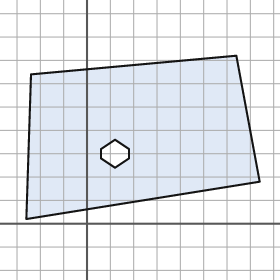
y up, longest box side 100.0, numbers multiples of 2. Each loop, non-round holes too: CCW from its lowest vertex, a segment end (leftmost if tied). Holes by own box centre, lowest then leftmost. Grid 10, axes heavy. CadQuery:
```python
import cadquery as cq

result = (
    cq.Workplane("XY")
    .moveTo(-26.0, 2.0)
    .lineTo(74.0, 18.0)
    .lineTo(64.0, 72.0)
    .lineTo(-24.0, 64.0)
    .close()
    .moveTo(12.0, 24.0)
    .lineTo(18.0, 28.0)
    .lineTo(18.0, 32.0)
    .lineTo(12.0, 36.0)
    .lineTo(6.0, 32.0)
    .lineTo(6.0, 28.0)
    .close()
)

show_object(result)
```